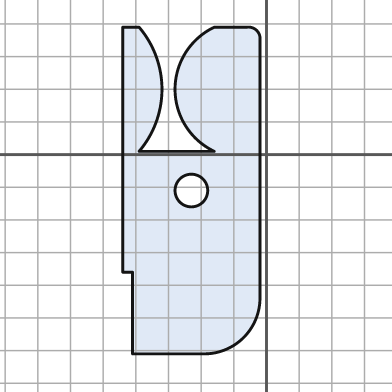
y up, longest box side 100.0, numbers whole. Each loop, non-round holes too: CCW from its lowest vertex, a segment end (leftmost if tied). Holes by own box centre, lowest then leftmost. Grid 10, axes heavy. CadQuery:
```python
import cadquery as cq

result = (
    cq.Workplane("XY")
    .moveTo(-41.0, -61.0)
    .lineTo(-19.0, -61.0)
    .threePointArc((-7.0, -56.0), (-2.0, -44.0))
    .lineTo(-2.0, 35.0)
    .threePointArc((-3.0, 38.0), (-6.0, 39.0))
    .lineTo(-16.0, 39.0)
    .threePointArc((-28.0, 20.0), (-16.0, 1.0))
    .lineTo(-39.0, 1.0)
    .threePointArc((-32.0, 20.0), (-39.0, 39.0))
    .lineTo(-44.0, 39.0)
    .lineTo(-44.0, -36.0)
    .lineTo(-41.0, -36.0)
    .close()
    .moveTo(-23.0, -11.0)
    .circle(5.0)
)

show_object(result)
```